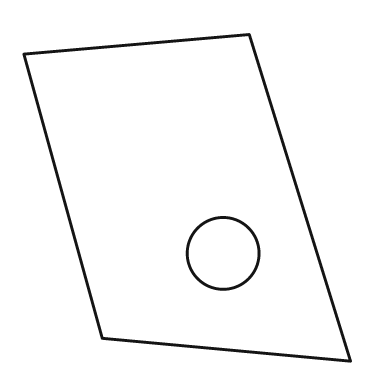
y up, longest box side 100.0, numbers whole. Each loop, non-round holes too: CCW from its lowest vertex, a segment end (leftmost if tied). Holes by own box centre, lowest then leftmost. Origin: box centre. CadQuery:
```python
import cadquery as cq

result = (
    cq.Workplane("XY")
    .moveTo(50.0, -50.0)
    .lineTo(19.0, 50.0)
    .lineTo(-50.0, 44.0)
    .lineTo(-26.0, -43.0)
    .close()
    .moveTo(11.0, -17.0)
    .circle(11.0)
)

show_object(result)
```